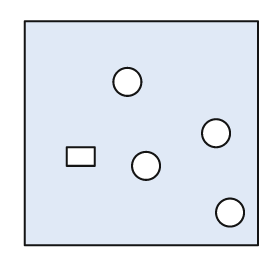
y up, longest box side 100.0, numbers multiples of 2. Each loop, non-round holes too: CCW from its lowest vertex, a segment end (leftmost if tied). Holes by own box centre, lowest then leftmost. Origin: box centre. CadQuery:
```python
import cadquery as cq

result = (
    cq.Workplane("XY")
    .moveTo(-50.0, -48.0)
    .lineTo(50.0, -48.0)
    .lineTo(50.0, 48.0)
    .lineTo(-50.0, 48.0)
    .close()
    .moveTo(38.0, -34.0)
    .circle(6.0)
    .moveTo(2.0, -14.0)
    .circle(6.0)
    .moveTo(-32.0, -14.0)
    .lineTo(-20.0, -14.0)
    .lineTo(-20.0, -6.0)
    .lineTo(-32.0, -6.0)
    .close()
    .moveTo(32.0, 0.0)
    .circle(6.0)
    .moveTo(-6.0, 22.0)
    .circle(6.0)
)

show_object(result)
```